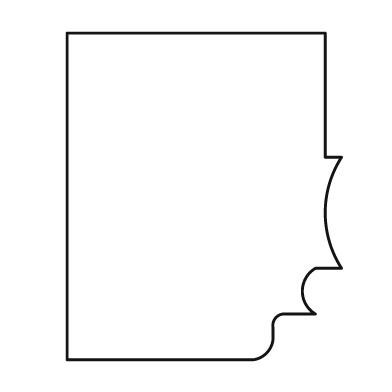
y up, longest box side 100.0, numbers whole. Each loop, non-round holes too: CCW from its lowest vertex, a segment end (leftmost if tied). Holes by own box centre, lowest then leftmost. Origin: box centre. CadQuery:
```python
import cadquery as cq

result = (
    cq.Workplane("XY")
    .moveTo(-42.0, -50.0)
    .lineTo(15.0, -50.0)
    .threePointArc((19.0, -48.0), (21.0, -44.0))
    .lineTo(21.0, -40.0)
    .threePointArc((22.0, -37.0), (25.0, -36.0))
    .lineTo(34.0, -36.0)
    .threePointArc((30.0, -29.0), (34.0, -22.0))
    .lineTo(42.0, -22.0)
    .threePointArc((37.0, -5.0), (42.0, 12.0))
    .lineTo(37.0, 12.0)
    .lineTo(37.0, 50.0)
    .lineTo(-42.0, 50.0)
    .close()
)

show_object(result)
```